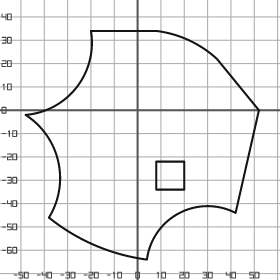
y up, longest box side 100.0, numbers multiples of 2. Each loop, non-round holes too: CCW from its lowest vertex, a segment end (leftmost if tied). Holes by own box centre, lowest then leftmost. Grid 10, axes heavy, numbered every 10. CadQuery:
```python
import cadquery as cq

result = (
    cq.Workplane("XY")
    .moveTo(4.0, -64.0)
    .threePointArc((18.0, -44.0), (42.0, -44.0))
    .lineTo(52.0, 0.0)
    .lineTo(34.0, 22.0)
    .threePointArc((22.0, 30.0), (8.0, 34.0))
    .lineTo(-20.0, 34.0)
    .threePointArc((-26.0, 10.0), (-48.0, -2.0))
    .threePointArc((-34.0, -22.0), (-38.0, -46.0))
    .threePointArc((-18.0, -58.0), (4.0, -64.0))
    .close()
    .moveTo(8.0, -34.0)
    .lineTo(20.0, -34.0)
    .lineTo(20.0, -22.0)
    .lineTo(8.0, -22.0)
    .close()
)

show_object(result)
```